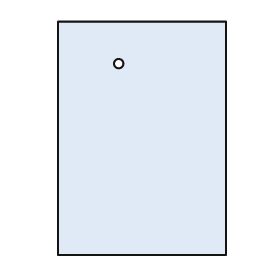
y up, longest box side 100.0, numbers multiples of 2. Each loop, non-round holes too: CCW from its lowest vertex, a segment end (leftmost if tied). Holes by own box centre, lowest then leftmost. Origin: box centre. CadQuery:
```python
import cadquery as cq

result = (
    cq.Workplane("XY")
    .moveTo(-36.0, -50.0)
    .lineTo(36.0, -50.0)
    .lineTo(36.0, 50.0)
    .lineTo(-36.0, 50.0)
    .close()
    .moveTo(-10.0, 32.0)
    .circle(2.0)
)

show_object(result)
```